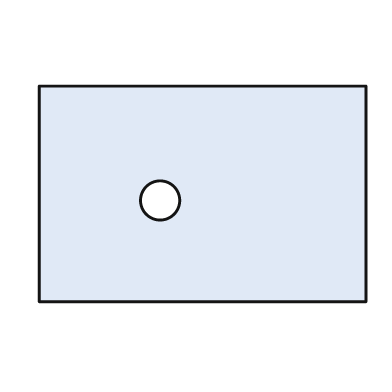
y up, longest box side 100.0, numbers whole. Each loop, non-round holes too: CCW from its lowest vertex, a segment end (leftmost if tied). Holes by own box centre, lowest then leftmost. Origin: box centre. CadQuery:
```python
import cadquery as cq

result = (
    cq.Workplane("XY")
    .moveTo(-50.0, -33.0)
    .lineTo(50.0, -33.0)
    .lineTo(50.0, 33.0)
    .lineTo(-50.0, 33.0)
    .close()
    .moveTo(-13.0, -2.0)
    .circle(6.0)
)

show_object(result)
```